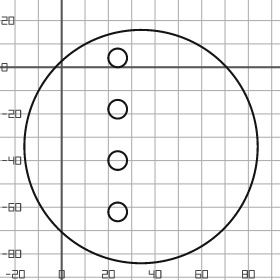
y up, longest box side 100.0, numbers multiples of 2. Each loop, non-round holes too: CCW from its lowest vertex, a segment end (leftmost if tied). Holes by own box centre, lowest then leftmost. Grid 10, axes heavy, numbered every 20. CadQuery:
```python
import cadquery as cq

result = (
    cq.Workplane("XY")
    .moveTo(34.0, -34.0)
    .circle(50.0)
    .moveTo(24.0, -62.0)
    .circle(4.0)
    .moveTo(24.0, -40.0)
    .circle(4.0)
    .moveTo(24.0, -18.0)
    .circle(4.0)
    .moveTo(24.0, 4.0)
    .circle(4.0)
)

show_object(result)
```